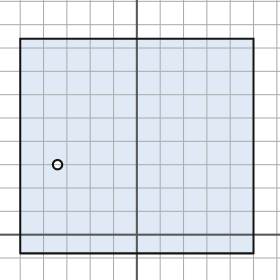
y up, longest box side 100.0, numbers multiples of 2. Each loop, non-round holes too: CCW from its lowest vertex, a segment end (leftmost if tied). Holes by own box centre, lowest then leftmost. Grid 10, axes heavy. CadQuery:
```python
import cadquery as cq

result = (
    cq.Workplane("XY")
    .moveTo(-50.0, -8.0)
    .lineTo(50.0, -8.0)
    .lineTo(50.0, 84.0)
    .lineTo(-50.0, 84.0)
    .close()
    .moveTo(-34.0, 30.0)
    .circle(2.0)
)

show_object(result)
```